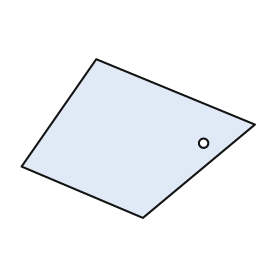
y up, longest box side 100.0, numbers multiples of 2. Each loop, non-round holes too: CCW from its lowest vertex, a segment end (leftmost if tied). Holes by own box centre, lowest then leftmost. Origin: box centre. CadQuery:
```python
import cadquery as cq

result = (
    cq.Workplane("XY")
    .moveTo(2.0, -34.0)
    .lineTo(50.0, 6.0)
    .lineTo(-18.0, 34.0)
    .lineTo(-50.0, -12.0)
    .close()
    .moveTo(28.0, -2.0)
    .circle(2.0)
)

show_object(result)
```